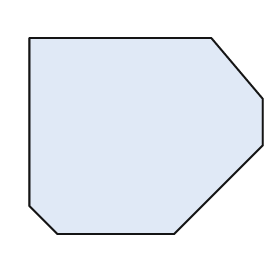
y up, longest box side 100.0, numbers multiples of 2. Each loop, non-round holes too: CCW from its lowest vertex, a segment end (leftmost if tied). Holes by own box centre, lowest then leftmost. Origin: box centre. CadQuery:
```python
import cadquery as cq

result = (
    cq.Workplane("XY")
    .moveTo(-38.0, -42.0)
    .lineTo(12.0, -42.0)
    .lineTo(50.0, -4.0)
    .lineTo(50.0, 16.0)
    .lineTo(28.0, 42.0)
    .lineTo(-50.0, 42.0)
    .lineTo(-50.0, -30.0)
    .close()
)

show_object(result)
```